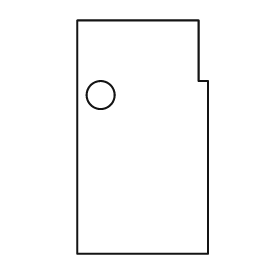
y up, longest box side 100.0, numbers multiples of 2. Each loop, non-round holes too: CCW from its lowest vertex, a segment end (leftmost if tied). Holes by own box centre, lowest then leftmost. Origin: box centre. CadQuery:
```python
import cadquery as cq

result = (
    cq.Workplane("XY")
    .moveTo(-28.0, -50.0)
    .lineTo(28.0, -50.0)
    .lineTo(28.0, 24.0)
    .lineTo(24.0, 24.0)
    .lineTo(24.0, 50.0)
    .lineTo(-28.0, 50.0)
    .close()
    .moveTo(-18.0, 18.0)
    .circle(6.0)
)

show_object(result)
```